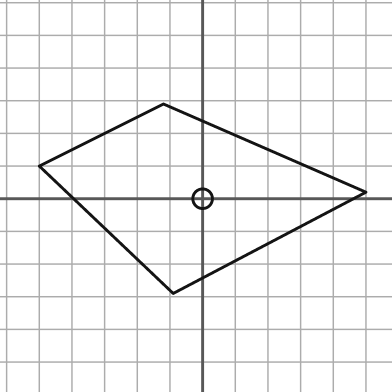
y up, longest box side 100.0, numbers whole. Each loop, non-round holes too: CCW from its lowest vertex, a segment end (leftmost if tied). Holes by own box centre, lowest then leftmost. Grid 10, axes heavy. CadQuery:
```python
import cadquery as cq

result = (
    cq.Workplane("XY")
    .moveTo(-9.0, -29.0)
    .lineTo(50.0, 2.0)
    .lineTo(-12.0, 29.0)
    .lineTo(-50.0, 10.0)
    .close()
    .moveTo(0.0, 0.0)
    .circle(3.0)
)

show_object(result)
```